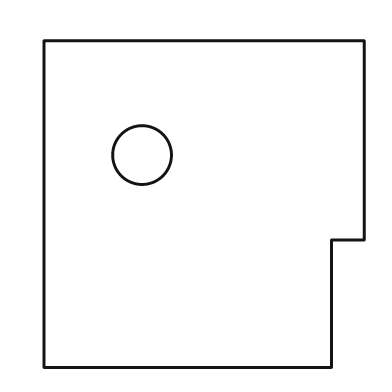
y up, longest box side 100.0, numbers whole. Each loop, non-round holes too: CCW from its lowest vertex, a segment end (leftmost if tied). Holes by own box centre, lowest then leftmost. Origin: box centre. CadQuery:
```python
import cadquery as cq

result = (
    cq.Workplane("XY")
    .moveTo(-49.0, -50.0)
    .lineTo(39.0, -50.0)
    .lineTo(39.0, -11.0)
    .lineTo(49.0, -11.0)
    .lineTo(49.0, 50.0)
    .lineTo(-49.0, 50.0)
    .close()
    .moveTo(-19.0, 15.0)
    .circle(9.0)
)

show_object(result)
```